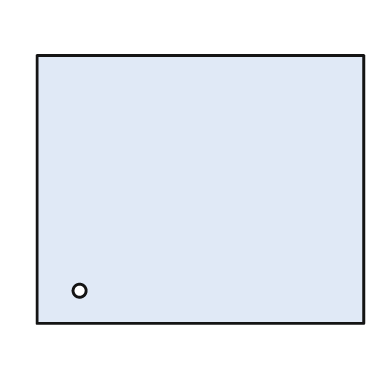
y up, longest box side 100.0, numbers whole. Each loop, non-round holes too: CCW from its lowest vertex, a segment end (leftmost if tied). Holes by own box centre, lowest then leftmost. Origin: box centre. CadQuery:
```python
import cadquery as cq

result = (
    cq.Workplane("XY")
    .moveTo(-50.0, -41.0)
    .lineTo(50.0, -41.0)
    .lineTo(50.0, 41.0)
    .lineTo(-50.0, 41.0)
    .close()
    .moveTo(-37.0, -31.0)
    .circle(2.0)
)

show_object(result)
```